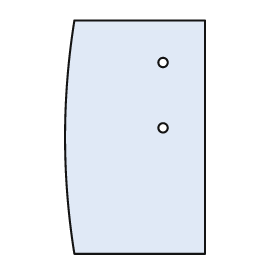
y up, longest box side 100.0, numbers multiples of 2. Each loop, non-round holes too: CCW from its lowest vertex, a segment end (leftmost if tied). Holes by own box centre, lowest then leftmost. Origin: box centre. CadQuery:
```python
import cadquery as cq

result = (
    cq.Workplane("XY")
    .moveTo(-26.0, -50.0)
    .lineTo(30.0, -50.0)
    .lineTo(30.0, 50.0)
    .lineTo(-26.0, 50.0)
    .threePointArc((-30.0, 0.0), (-26.0, -50.0))
    .close()
    .moveTo(12.0, 4.0)
    .circle(2.0)
    .moveTo(12.0, 32.0)
    .circle(2.0)
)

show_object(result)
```